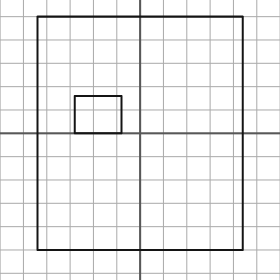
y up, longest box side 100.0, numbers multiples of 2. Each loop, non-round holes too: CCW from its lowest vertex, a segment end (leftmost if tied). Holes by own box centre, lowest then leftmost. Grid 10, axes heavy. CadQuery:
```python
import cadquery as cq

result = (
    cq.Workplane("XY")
    .moveTo(-44.0, -50.0)
    .lineTo(44.0, -50.0)
    .lineTo(44.0, 50.0)
    .lineTo(-44.0, 50.0)
    .close()
    .moveTo(-28.0, 0.0)
    .lineTo(-8.0, 0.0)
    .lineTo(-8.0, 16.0)
    .lineTo(-28.0, 16.0)
    .close()
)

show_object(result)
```